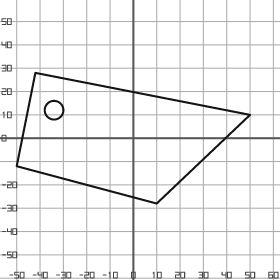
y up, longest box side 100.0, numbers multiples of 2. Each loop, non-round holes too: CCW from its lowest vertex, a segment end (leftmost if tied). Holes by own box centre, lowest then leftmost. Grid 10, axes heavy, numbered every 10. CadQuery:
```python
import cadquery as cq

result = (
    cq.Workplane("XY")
    .moveTo(10.0, -28.0)
    .lineTo(50.0, 10.0)
    .lineTo(-42.0, 28.0)
    .lineTo(-50.0, -12.0)
    .close()
    .moveTo(-34.0, 12.0)
    .circle(4.0)
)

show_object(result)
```